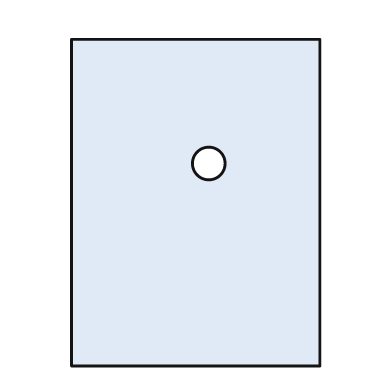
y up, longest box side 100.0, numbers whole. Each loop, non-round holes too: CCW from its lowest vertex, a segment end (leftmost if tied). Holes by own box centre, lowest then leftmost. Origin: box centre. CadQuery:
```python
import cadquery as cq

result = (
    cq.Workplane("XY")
    .moveTo(-38.0, -50.0)
    .lineTo(38.0, -50.0)
    .lineTo(38.0, 50.0)
    .lineTo(-38.0, 50.0)
    .close()
    .moveTo(4.0, 12.0)
    .circle(5.0)
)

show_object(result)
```